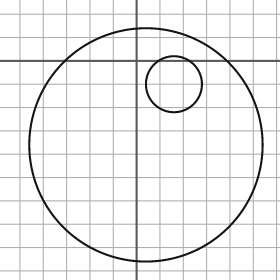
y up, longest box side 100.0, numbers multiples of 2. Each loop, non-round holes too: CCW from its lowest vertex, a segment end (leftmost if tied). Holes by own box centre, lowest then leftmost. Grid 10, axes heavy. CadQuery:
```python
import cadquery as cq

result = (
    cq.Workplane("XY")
    .moveTo(4.0, -36.0)
    .circle(50.0)
    .moveTo(16.0, -10.0)
    .circle(12.0)
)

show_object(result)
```